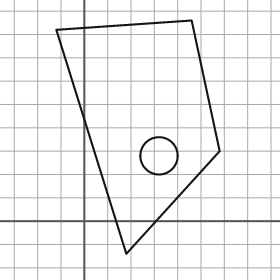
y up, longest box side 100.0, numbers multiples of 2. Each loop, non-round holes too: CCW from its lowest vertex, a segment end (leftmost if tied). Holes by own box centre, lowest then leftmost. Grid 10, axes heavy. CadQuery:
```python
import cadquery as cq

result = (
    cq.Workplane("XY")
    .moveTo(18.0, -14.0)
    .lineTo(58.0, 30.0)
    .lineTo(46.0, 86.0)
    .lineTo(-12.0, 82.0)
    .close()
    .moveTo(32.0, 28.0)
    .circle(8.0)
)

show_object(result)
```